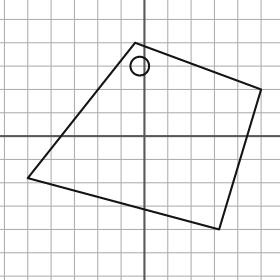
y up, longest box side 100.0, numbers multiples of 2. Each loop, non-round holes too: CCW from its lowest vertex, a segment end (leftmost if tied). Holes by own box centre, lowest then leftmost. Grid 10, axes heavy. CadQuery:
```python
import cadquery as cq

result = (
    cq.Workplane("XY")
    .moveTo(32.0, -40.0)
    .lineTo(50.0, 20.0)
    .lineTo(-4.0, 40.0)
    .lineTo(-50.0, -18.0)
    .close()
    .moveTo(-2.0, 30.0)
    .circle(4.0)
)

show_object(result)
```